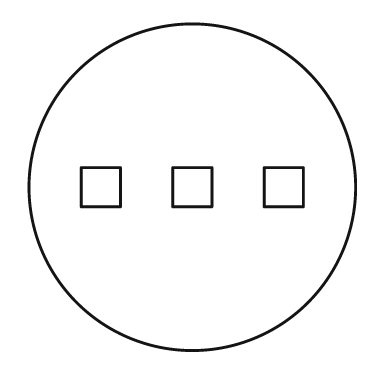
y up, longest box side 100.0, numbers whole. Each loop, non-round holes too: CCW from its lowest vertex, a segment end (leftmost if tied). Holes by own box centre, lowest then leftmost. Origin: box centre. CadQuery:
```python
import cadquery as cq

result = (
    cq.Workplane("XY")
    .moveTo(0.0, 0.0)
    .circle(50.0)
    .moveTo(-34.0, -6.0)
    .lineTo(-22.0, -6.0)
    .lineTo(-22.0, 6.0)
    .lineTo(-34.0, 6.0)
    .close()
    .moveTo(-6.0, -6.0)
    .lineTo(6.0, -6.0)
    .lineTo(6.0, 6.0)
    .lineTo(-6.0, 6.0)
    .close()
    .moveTo(22.0, -6.0)
    .lineTo(34.0, -6.0)
    .lineTo(34.0, 6.0)
    .lineTo(22.0, 6.0)
    .close()
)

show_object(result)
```